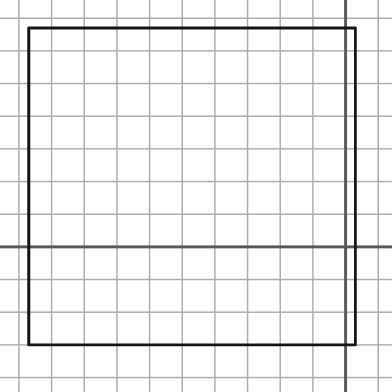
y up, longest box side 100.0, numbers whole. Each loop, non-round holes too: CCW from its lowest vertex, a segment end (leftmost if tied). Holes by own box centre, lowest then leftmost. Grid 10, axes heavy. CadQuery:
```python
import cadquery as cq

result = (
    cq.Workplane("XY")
    .moveTo(-97.0, -30.0)
    .lineTo(3.0, -30.0)
    .lineTo(3.0, 67.0)
    .lineTo(-97.0, 67.0)
    .close()
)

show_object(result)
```